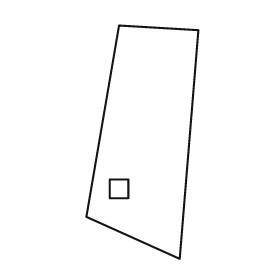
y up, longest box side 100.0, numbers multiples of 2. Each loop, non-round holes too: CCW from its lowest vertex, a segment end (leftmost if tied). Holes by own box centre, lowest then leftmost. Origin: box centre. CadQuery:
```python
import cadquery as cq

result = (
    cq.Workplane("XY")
    .moveTo(16.0, -50.0)
    .lineTo(24.0, 48.0)
    .lineTo(-10.0, 50.0)
    .lineTo(-24.0, -32.0)
    .close()
    .moveTo(-14.0, -24.0)
    .lineTo(-6.0, -24.0)
    .lineTo(-6.0, -16.0)
    .lineTo(-14.0, -16.0)
    .close()
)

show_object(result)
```